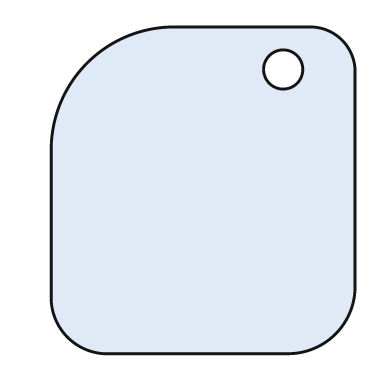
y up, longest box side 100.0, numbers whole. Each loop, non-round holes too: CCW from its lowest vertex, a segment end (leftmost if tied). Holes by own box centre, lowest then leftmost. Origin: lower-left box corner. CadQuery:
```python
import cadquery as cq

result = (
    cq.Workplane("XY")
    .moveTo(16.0, 0.0)
    .lineTo(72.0, 0.0)
    .threePointArc((87.0, 6.0), (93.0, 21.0))
    .lineTo(93.0, 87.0)
    .threePointArc((89.0, 96.0), (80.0, 100.0))
    .lineTo(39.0, 100.0)
    .threePointArc((11.0, 89.0), (0.0, 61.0))
    .lineTo(0.0, 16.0)
    .threePointArc((5.0, 5.0), (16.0, 0.0))
    .close()
    .moveTo(71.0, 87.0)
    .circle(6.0)
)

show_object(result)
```